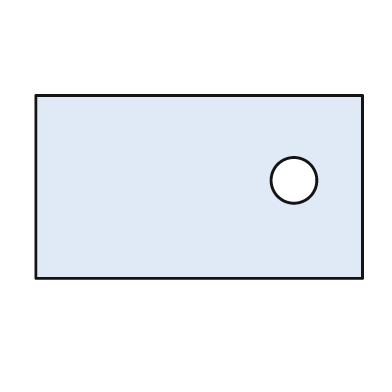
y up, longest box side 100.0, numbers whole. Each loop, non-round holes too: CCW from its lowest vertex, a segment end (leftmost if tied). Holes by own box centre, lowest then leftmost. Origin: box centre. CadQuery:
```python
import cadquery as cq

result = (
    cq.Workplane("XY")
    .moveTo(-50.0, -28.0)
    .lineTo(50.0, -28.0)
    .lineTo(50.0, 28.0)
    .lineTo(-50.0, 28.0)
    .close()
    .moveTo(29.0, 2.0)
    .circle(7.0)
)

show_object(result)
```